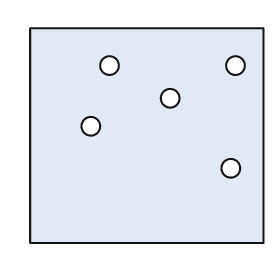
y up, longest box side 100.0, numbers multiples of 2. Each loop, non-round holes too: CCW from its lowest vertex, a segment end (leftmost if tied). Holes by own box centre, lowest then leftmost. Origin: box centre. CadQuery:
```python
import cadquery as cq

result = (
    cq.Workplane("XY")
    .moveTo(-50.0, -46.0)
    .lineTo(50.0, -46.0)
    .lineTo(50.0, 46.0)
    .lineTo(-50.0, 46.0)
    .close()
    .moveTo(36.0, -14.0)
    .circle(4.0)
    .moveTo(-24.0, 4.0)
    .circle(4.0)
    .moveTo(10.0, 16.0)
    .circle(4.0)
    .moveTo(-16.0, 30.0)
    .circle(4.0)
    .moveTo(38.0, 30.0)
    .circle(4.0)
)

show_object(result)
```